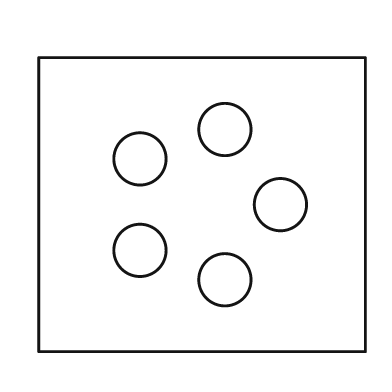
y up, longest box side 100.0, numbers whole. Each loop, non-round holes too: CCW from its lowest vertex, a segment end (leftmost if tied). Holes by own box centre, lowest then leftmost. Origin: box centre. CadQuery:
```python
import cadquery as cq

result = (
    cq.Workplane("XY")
    .moveTo(-50.0, -45.0)
    .lineTo(50.0, -45.0)
    .lineTo(50.0, 45.0)
    .lineTo(-50.0, 45.0)
    .close()
    .moveTo(7.0, -23.0)
    .circle(8.0)
    .moveTo(-19.0, -14.0)
    .circle(8.0)
    .moveTo(24.0, 0.0)
    .circle(8.0)
    .moveTo(-19.0, 14.0)
    .circle(8.0)
    .moveTo(7.0, 23.0)
    .circle(8.0)
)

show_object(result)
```